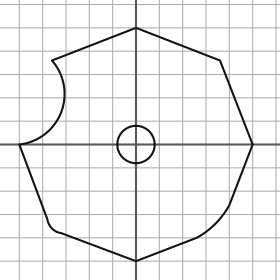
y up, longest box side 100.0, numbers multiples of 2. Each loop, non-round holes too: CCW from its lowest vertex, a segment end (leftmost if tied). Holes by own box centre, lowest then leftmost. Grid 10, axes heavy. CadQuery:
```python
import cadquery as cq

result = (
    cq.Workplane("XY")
    .moveTo(0.0, -50.0)
    .lineTo(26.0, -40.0)
    .threePointArc((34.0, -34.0), (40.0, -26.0))
    .lineTo(50.0, 0.0)
    .lineTo(36.0, 36.0)
    .lineTo(0.0, 50.0)
    .lineTo(-36.0, 36.0)
    .threePointArc((-32.0, 14.0), (-50.0, 0.0))
    .lineTo(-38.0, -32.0)
    .threePointArc((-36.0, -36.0), (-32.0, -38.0))
    .close()
    .moveTo(0.0, 0.0)
    .circle(8.0)
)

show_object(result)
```